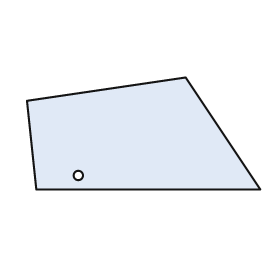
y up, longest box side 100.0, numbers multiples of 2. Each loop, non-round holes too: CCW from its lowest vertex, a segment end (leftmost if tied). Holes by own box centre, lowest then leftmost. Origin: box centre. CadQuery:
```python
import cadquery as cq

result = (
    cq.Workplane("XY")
    .moveTo(-46.0, -24.0)
    .lineTo(50.0, -24.0)
    .lineTo(18.0, 24.0)
    .lineTo(-50.0, 14.0)
    .close()
    .moveTo(-28.0, -18.0)
    .circle(2.0)
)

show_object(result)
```